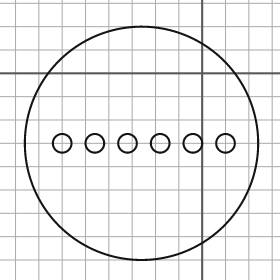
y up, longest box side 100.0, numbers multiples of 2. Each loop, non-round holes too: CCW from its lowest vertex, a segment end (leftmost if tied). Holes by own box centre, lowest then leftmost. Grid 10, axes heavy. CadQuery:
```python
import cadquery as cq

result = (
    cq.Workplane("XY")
    .moveTo(-26.0, -30.0)
    .circle(50.0)
    .moveTo(-60.0, -30.0)
    .circle(4.0)
    .moveTo(-46.0, -30.0)
    .circle(4.0)
    .moveTo(-32.0, -30.0)
    .circle(4.0)
    .moveTo(-18.0, -30.0)
    .circle(4.0)
    .moveTo(-4.0, -30.0)
    .circle(4.0)
    .moveTo(10.0, -30.0)
    .circle(4.0)
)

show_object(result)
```